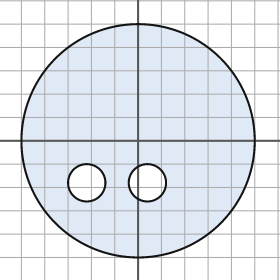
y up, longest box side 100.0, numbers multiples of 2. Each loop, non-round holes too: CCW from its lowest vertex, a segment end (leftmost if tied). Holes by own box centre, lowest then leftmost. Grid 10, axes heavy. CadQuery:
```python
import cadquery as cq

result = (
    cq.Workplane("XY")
    .moveTo(0.0, 0.0)
    .circle(50.0)
    .moveTo(-22.0, -18.0)
    .circle(8.0)
    .moveTo(4.0, -18.0)
    .circle(8.0)
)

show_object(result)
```